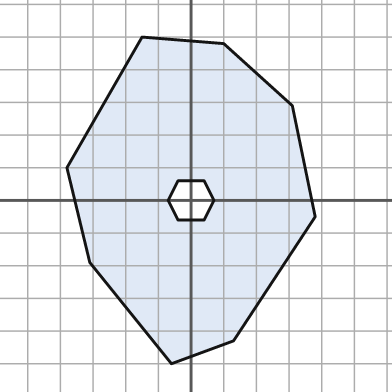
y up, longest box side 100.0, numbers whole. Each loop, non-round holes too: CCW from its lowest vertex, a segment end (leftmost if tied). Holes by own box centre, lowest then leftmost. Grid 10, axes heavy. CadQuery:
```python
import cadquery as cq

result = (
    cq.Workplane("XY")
    .moveTo(-6.0, -50.0)
    .lineTo(13.0, -43.0)
    .lineTo(38.0, -5.0)
    .lineTo(31.0, 29.0)
    .lineTo(10.0, 48.0)
    .lineTo(-15.0, 50.0)
    .lineTo(-38.0, 10.0)
    .lineTo(-31.0, -19.0)
    .close()
    .moveTo(-4.0, -6.0)
    .lineTo(4.0, -6.0)
    .lineTo(7.0, 0.0)
    .lineTo(4.0, 6.0)
    .lineTo(-4.0, 6.0)
    .lineTo(-7.0, 0.0)
    .close()
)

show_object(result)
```